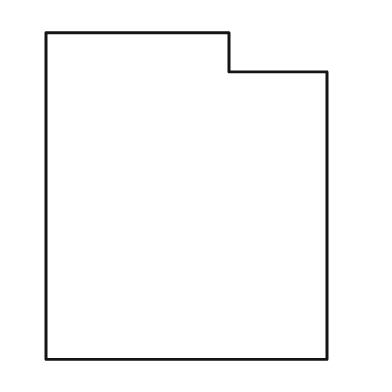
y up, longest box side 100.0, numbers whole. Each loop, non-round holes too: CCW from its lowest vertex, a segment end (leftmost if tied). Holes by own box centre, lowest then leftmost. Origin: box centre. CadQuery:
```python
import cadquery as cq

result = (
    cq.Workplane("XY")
    .moveTo(-43.0, -50.0)
    .lineTo(43.0, -50.0)
    .lineTo(43.0, 38.0)
    .lineTo(13.0, 38.0)
    .lineTo(13.0, 50.0)
    .lineTo(-43.0, 50.0)
    .close()
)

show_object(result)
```